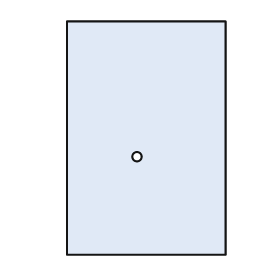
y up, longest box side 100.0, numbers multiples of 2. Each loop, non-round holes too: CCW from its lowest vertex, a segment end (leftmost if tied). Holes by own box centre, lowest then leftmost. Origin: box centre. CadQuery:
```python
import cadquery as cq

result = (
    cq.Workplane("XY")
    .moveTo(-34.0, -50.0)
    .lineTo(34.0, -50.0)
    .lineTo(34.0, 50.0)
    .lineTo(-34.0, 50.0)
    .close()
    .moveTo(-4.0, -8.0)
    .circle(2.0)
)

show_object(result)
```